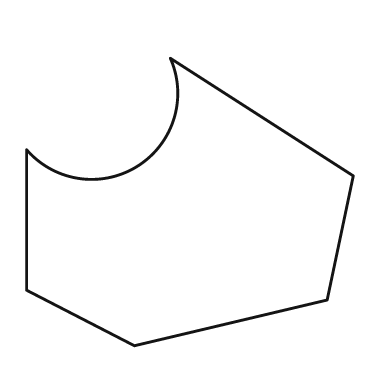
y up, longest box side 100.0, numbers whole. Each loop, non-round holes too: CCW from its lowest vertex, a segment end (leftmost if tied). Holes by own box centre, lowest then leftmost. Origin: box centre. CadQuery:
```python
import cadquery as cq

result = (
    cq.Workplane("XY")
    .moveTo(-17.0, -44.0)
    .lineTo(42.0, -30.0)
    .lineTo(50.0, 8.0)
    .lineTo(-6.0, 44.0)
    .threePointArc((-16.0, 11.0), (-50.0, 16.0))
    .lineTo(-50.0, -27.0)
    .close()
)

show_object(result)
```